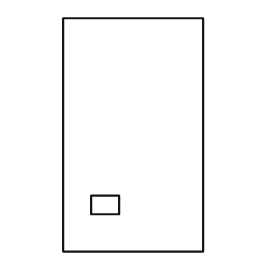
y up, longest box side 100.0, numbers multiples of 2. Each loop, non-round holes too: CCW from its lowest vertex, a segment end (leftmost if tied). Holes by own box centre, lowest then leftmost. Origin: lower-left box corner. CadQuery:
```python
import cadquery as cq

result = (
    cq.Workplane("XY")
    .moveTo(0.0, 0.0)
    .lineTo(60.0, 0.0)
    .lineTo(60.0, 100.0)
    .lineTo(0.0, 100.0)
    .close()
    .moveTo(12.0, 16.0)
    .lineTo(24.0, 16.0)
    .lineTo(24.0, 24.0)
    .lineTo(12.0, 24.0)
    .close()
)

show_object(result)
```